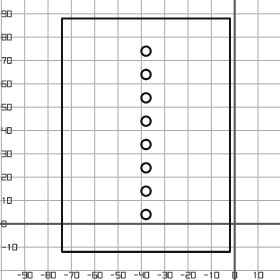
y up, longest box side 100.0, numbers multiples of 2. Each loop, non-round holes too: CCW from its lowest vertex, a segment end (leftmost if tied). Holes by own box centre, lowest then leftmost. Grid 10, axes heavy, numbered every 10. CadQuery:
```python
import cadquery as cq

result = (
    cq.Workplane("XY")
    .moveTo(-74.0, -12.0)
    .lineTo(-2.0, -12.0)
    .lineTo(-2.0, 88.0)
    .lineTo(-74.0, 88.0)
    .close()
    .moveTo(-38.0, 4.0)
    .circle(2.0)
    .moveTo(-38.0, 14.0)
    .circle(2.0)
    .moveTo(-38.0, 24.0)
    .circle(2.0)
    .moveTo(-38.0, 34.0)
    .circle(2.0)
    .moveTo(-38.0, 44.0)
    .circle(2.0)
    .moveTo(-38.0, 54.0)
    .circle(2.0)
    .moveTo(-38.0, 64.0)
    .circle(2.0)
    .moveTo(-38.0, 74.0)
    .circle(2.0)
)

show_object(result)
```